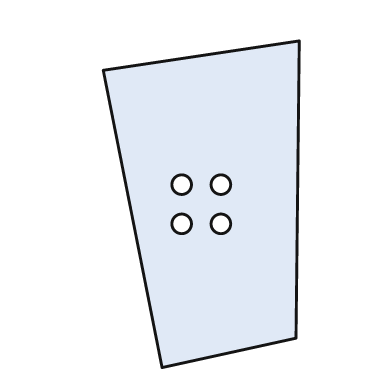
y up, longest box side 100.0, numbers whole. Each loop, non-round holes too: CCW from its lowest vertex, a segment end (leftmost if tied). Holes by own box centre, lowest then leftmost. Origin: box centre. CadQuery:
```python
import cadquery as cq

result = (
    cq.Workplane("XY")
    .moveTo(-12.0, -50.0)
    .lineTo(29.0, -41.0)
    .lineTo(30.0, 50.0)
    .lineTo(-30.0, 41.0)
    .close()
    .moveTo(-6.0, -6.0)
    .circle(3.0)
    .moveTo(6.0, -6.0)
    .circle(3.0)
    .moveTo(-6.0, 6.0)
    .circle(3.0)
    .moveTo(6.0, 6.0)
    .circle(3.0)
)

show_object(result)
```